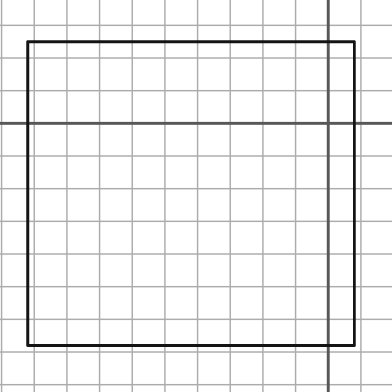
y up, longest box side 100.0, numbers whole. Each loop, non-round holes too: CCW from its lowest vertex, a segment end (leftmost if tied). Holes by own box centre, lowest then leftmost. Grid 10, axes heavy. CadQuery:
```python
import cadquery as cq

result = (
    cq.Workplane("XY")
    .moveTo(-92.0, -68.0)
    .lineTo(8.0, -68.0)
    .lineTo(8.0, 25.0)
    .lineTo(-92.0, 25.0)
    .close()
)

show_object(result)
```